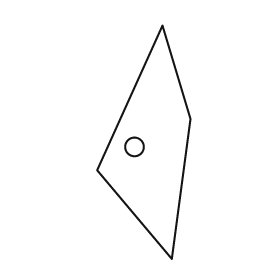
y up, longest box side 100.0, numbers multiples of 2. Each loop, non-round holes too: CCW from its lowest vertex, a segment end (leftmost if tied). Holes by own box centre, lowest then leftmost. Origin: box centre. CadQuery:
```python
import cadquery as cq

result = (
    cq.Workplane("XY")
    .moveTo(12.0, -50.0)
    .lineTo(20.0, 10.0)
    .lineTo(8.0, 50.0)
    .lineTo(-20.0, -12.0)
    .close()
    .moveTo(-4.0, -2.0)
    .circle(4.0)
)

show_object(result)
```